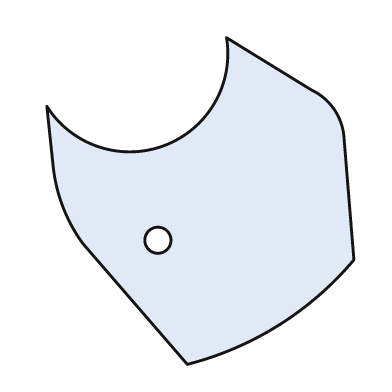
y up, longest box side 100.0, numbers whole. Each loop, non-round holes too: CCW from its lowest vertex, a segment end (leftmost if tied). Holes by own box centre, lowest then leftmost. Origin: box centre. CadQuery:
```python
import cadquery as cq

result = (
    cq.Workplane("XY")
    .moveTo(-4.0, -50.0)
    .threePointArc((24.0, -38.0), (47.0, -18.0))
    .lineTo(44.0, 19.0)
    .threePointArc((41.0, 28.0), (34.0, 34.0))
    .lineTo(8.0, 50.0)
    .threePointArc((-11.0, 17.0), (-47.0, 29.0))
    .lineTo(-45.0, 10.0)
    .threePointArc((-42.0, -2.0), (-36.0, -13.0))
    .close()
    .moveTo(-13.0, -12.0)
    .circle(4.0)
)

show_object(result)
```